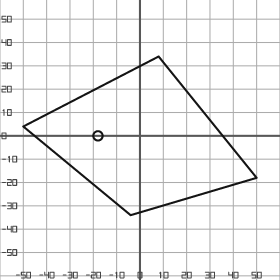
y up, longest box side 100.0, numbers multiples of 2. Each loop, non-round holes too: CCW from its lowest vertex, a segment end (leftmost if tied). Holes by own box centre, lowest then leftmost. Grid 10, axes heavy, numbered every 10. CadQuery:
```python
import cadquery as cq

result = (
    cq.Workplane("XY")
    .moveTo(-4.0, -34.0)
    .lineTo(50.0, -18.0)
    .lineTo(8.0, 34.0)
    .lineTo(-50.0, 4.0)
    .close()
    .moveTo(-18.0, 0.0)
    .circle(2.0)
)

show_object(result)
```